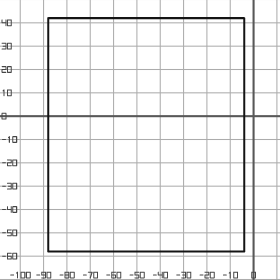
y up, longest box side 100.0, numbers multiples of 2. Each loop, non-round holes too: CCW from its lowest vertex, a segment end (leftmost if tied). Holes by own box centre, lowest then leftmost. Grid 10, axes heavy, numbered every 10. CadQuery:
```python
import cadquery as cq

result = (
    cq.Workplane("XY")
    .moveTo(-88.0, -58.0)
    .lineTo(-4.0, -58.0)
    .lineTo(-4.0, 42.0)
    .lineTo(-88.0, 42.0)
    .close()
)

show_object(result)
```